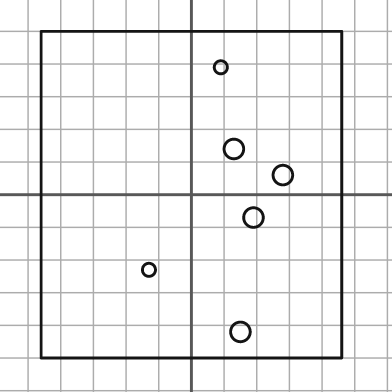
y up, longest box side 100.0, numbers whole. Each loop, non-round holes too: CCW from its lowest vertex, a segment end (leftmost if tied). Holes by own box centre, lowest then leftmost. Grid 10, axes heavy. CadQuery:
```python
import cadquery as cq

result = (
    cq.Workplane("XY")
    .moveTo(-46.0, -50.0)
    .lineTo(46.0, -50.0)
    .lineTo(46.0, 50.0)
    .lineTo(-46.0, 50.0)
    .close()
    .moveTo(15.0, -42.0)
    .circle(3.0)
    .moveTo(-13.0, -23.0)
    .circle(2.0)
    .moveTo(19.0, -7.0)
    .circle(3.0)
    .moveTo(28.0, 6.0)
    .circle(3.0)
    .moveTo(13.0, 14.0)
    .circle(3.0)
    .moveTo(9.0, 39.0)
    .circle(2.0)
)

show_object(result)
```